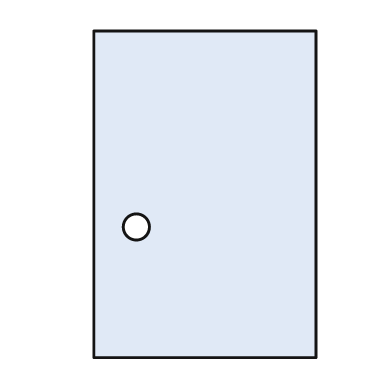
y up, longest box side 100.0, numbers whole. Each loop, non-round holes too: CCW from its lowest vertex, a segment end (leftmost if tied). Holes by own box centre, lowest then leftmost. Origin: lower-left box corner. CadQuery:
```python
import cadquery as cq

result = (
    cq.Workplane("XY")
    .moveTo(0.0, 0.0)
    .lineTo(68.0, 0.0)
    .lineTo(68.0, 100.0)
    .lineTo(0.0, 100.0)
    .close()
    .moveTo(13.0, 40.0)
    .circle(4.0)
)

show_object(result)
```